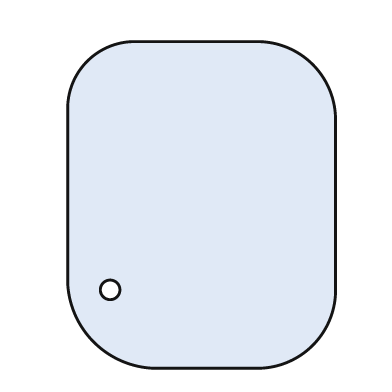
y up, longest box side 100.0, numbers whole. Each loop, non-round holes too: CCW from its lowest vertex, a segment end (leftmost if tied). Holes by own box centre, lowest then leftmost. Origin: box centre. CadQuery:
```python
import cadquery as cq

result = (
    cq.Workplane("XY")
    .moveTo(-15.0, -50.0)
    .lineTo(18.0, -50.0)
    .threePointArc((34.0, -43.0), (41.0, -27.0))
    .lineTo(41.0, 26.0)
    .threePointArc((34.0, 43.0), (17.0, 50.0))
    .lineTo(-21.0, 50.0)
    .threePointArc((-35.0, 44.0), (-41.0, 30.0))
    .lineTo(-41.0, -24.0)
    .threePointArc((-33.0, -42.0), (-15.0, -50.0))
    .close()
    .moveTo(-28.0, -26.0)
    .circle(3.0)
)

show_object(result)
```